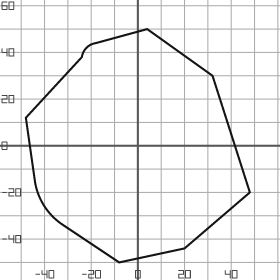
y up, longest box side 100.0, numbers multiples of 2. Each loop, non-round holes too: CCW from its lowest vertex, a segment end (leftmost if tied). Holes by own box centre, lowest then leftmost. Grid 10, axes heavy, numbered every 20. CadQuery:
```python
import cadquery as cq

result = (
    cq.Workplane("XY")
    .moveTo(-8.0, -50.0)
    .lineTo(20.0, -44.0)
    .lineTo(48.0, -20.0)
    .lineTo(32.0, 30.0)
    .lineTo(4.0, 50.0)
    .lineTo(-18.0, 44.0)
    .threePointArc((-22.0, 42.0), (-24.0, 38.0))
    .lineTo(-48.0, 12.0)
    .lineTo(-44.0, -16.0)
    .threePointArc((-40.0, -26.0), (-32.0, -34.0))
    .close()
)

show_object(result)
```